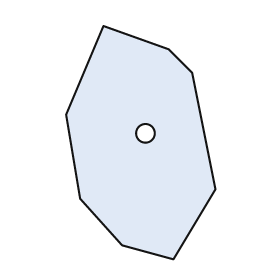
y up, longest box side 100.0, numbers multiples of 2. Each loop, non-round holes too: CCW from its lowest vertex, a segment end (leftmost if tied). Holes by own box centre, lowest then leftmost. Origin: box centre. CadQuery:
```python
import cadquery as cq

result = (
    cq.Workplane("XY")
    .moveTo(14.0, -50.0)
    .lineTo(32.0, -20.0)
    .lineTo(22.0, 30.0)
    .lineTo(12.0, 40.0)
    .lineTo(-16.0, 50.0)
    .lineTo(-32.0, 12.0)
    .lineTo(-26.0, -24.0)
    .lineTo(-8.0, -44.0)
    .close()
    .moveTo(2.0, 4.0)
    .circle(4.0)
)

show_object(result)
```